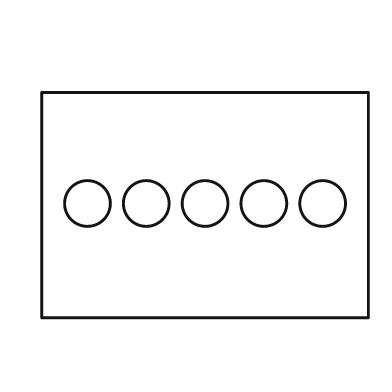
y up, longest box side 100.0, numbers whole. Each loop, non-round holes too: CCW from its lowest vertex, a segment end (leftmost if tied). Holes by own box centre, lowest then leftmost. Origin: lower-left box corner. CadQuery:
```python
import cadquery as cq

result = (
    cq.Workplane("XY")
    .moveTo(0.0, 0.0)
    .lineTo(100.0, 0.0)
    .lineTo(100.0, 69.0)
    .lineTo(0.0, 69.0)
    .close()
    .moveTo(14.0, 35.0)
    .circle(7.0)
    .moveTo(32.0, 35.0)
    .circle(7.0)
    .moveTo(50.0, 35.0)
    .circle(7.0)
    .moveTo(68.0, 35.0)
    .circle(7.0)
    .moveTo(86.0, 35.0)
    .circle(7.0)
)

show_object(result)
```